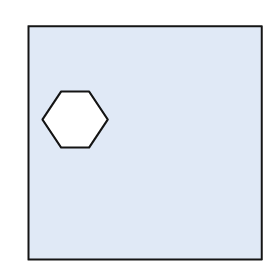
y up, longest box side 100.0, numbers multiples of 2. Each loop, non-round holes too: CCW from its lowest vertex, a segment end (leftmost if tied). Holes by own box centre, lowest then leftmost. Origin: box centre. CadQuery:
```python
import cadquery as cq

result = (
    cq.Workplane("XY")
    .moveTo(-50.0, -50.0)
    .lineTo(50.0, -50.0)
    .lineTo(50.0, 50.0)
    .lineTo(-50.0, 50.0)
    .close()
    .moveTo(-36.0, -2.0)
    .lineTo(-24.0, -2.0)
    .lineTo(-16.0, 10.0)
    .lineTo(-24.0, 22.0)
    .lineTo(-36.0, 22.0)
    .lineTo(-44.0, 10.0)
    .close()
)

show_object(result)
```